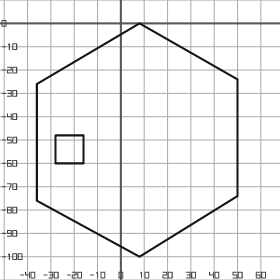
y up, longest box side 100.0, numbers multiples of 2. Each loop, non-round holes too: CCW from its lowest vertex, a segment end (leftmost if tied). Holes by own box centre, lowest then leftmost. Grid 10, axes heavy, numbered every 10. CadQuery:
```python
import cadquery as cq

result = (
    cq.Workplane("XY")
    .moveTo(8.0, -100.0)
    .lineTo(50.0, -74.0)
    .lineTo(50.0, -24.0)
    .lineTo(8.0, 0.0)
    .lineTo(-36.0, -26.0)
    .lineTo(-36.0, -76.0)
    .close()
    .moveTo(-28.0, -60.0)
    .lineTo(-16.0, -60.0)
    .lineTo(-16.0, -48.0)
    .lineTo(-28.0, -48.0)
    .close()
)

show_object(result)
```